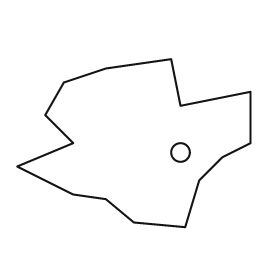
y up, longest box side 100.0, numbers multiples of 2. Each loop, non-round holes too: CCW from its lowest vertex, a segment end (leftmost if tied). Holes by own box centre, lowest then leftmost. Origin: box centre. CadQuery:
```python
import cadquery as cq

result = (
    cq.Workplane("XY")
    .moveTo(22.0, -36.0)
    .lineTo(28.0, -16.0)
    .lineTo(38.0, -6.0)
    .lineTo(50.0, 0.0)
    .lineTo(50.0, 22.0)
    .lineTo(20.0, 16.0)
    .lineTo(16.0, 36.0)
    .lineTo(-12.0, 32.0)
    .lineTo(-30.0, 26.0)
    .lineTo(-38.0, 12.0)
    .lineTo(-26.0, 0.0)
    .lineTo(-50.0, -10.0)
    .lineTo(-26.0, -22.0)
    .lineTo(-12.0, -24.0)
    .lineTo(0.0, -34.0)
    .close()
    .moveTo(20.0, -4.0)
    .circle(4.0)
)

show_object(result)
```